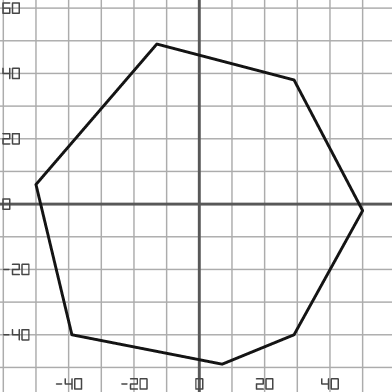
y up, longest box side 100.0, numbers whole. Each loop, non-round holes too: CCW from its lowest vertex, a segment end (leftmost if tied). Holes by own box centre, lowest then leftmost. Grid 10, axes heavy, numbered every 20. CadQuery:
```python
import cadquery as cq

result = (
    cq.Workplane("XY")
    .moveTo(7.0, -49.0)
    .lineTo(29.0, -40.0)
    .lineTo(50.0, -2.0)
    .lineTo(29.0, 38.0)
    .lineTo(-13.0, 49.0)
    .lineTo(-50.0, 6.0)
    .lineTo(-39.0, -40.0)
    .close()
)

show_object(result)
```